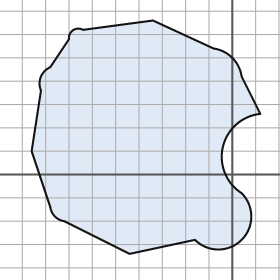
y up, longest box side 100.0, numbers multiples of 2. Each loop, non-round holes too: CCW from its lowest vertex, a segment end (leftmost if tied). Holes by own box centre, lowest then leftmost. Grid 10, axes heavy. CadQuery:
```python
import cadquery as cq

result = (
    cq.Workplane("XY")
    .moveTo(-44.0, -34.0)
    .lineTo(-16.0, -28.0)
    .threePointArc((4.0, -28.0), (4.0, -8.0))
    .threePointArc((-4.0, 12.0), (12.0, 26.0))
    .lineTo(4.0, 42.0)
    .threePointArc((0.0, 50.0), (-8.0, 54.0))
    .lineTo(-34.0, 66.0)
    .lineTo(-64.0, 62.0)
    .threePointArc((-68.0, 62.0), (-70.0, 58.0))
    .lineTo(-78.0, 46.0)
    .threePointArc((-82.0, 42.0), (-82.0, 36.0))
    .lineTo(-86.0, 10.0)
    .lineTo(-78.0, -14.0)
    .threePointArc((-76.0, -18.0), (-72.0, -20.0))
    .close()
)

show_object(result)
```